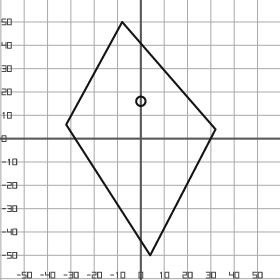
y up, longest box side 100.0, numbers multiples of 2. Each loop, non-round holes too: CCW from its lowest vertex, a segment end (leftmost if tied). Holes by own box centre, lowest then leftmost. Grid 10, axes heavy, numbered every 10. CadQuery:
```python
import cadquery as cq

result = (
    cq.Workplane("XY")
    .moveTo(4.0, -50.0)
    .lineTo(32.0, 4.0)
    .lineTo(-8.0, 50.0)
    .lineTo(-32.0, 6.0)
    .close()
    .moveTo(0.0, 16.0)
    .circle(2.0)
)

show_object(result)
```